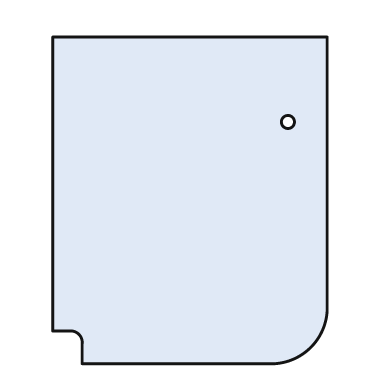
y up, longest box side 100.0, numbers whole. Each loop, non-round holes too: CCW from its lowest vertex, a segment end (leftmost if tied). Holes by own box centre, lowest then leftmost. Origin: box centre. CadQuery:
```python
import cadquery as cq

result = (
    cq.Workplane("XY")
    .moveTo(-33.0, -50.0)
    .lineTo(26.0, -50.0)
    .threePointArc((37.0, -45.0), (42.0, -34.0))
    .lineTo(42.0, 50.0)
    .lineTo(-42.0, 50.0)
    .lineTo(-42.0, -40.0)
    .lineTo(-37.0, -40.0)
    .threePointArc((-34.0, -41.0), (-33.0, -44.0))
    .close()
    .moveTo(30.0, 24.0)
    .circle(2.0)
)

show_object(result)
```